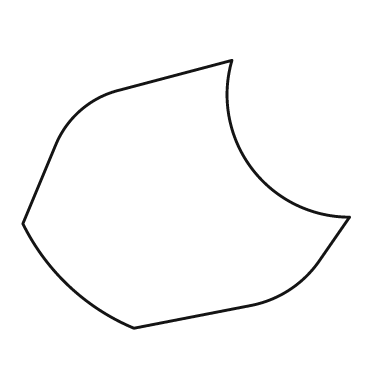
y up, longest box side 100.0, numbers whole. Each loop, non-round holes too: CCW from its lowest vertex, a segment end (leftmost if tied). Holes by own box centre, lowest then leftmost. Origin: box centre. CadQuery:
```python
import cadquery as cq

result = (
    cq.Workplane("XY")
    .moveTo(-16.0, -41.0)
    .lineTo(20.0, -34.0)
    .threePointArc((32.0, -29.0), (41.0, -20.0))
    .lineTo(50.0, -7.0)
    .threePointArc((20.0, 8.0), (14.0, 41.0))
    .lineTo(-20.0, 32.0)
    .threePointArc((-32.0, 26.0), (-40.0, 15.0))
    .lineTo(-50.0, -9.0)
    .threePointArc((-36.0, -28.0), (-16.0, -41.0))
    .close()
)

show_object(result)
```